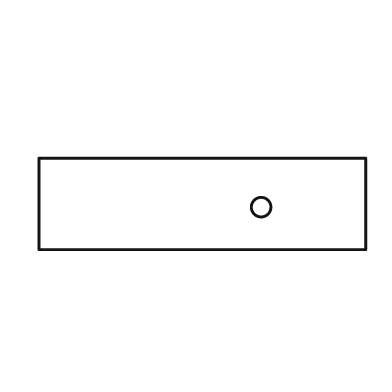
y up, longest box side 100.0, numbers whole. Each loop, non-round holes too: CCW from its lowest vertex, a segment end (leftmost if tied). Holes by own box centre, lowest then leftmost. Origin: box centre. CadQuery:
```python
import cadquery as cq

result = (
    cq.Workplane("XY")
    .moveTo(-50.0, -14.0)
    .lineTo(50.0, -14.0)
    .lineTo(50.0, 14.0)
    .lineTo(-50.0, 14.0)
    .close()
    .moveTo(18.0, -1.0)
    .circle(3.0)
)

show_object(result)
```